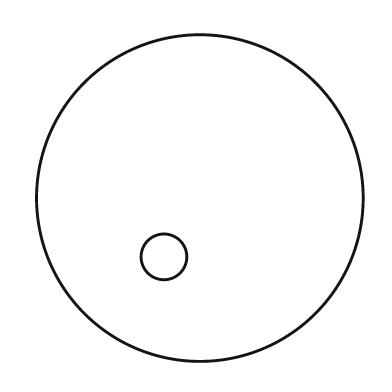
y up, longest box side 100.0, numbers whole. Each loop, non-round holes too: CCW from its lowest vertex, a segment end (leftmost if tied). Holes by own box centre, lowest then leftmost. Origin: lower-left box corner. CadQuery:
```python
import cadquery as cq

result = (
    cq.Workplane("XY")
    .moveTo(50.0, 50.0)
    .circle(50.0)
    .moveTo(39.0, 32.0)
    .circle(7.0)
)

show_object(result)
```